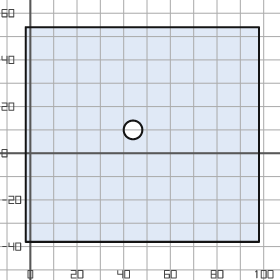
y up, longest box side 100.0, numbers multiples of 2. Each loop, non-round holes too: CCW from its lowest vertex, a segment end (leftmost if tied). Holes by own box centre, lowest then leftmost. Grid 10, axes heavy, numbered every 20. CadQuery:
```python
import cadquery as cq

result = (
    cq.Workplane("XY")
    .moveTo(-2.0, -38.0)
    .lineTo(98.0, -38.0)
    .lineTo(98.0, 54.0)
    .lineTo(-2.0, 54.0)
    .close()
    .moveTo(44.0, 10.0)
    .circle(4.0)
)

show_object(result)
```